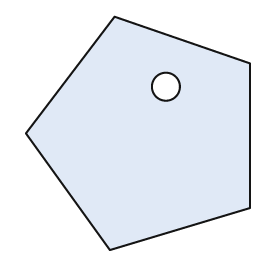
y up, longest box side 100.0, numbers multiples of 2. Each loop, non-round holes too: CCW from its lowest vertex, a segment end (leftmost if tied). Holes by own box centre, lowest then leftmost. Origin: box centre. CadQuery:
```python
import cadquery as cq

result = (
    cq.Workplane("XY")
    .moveTo(-12.0, -50.0)
    .lineTo(48.0, -32.0)
    .lineTo(48.0, 30.0)
    .lineTo(-10.0, 50.0)
    .lineTo(-48.0, 0.0)
    .close()
    .moveTo(12.0, 20.0)
    .circle(6.0)
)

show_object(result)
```